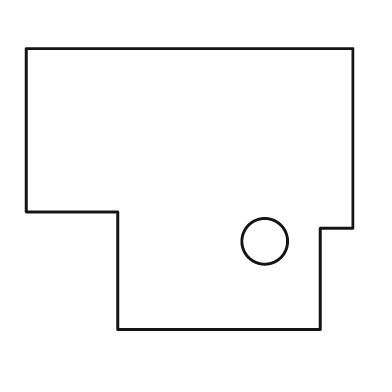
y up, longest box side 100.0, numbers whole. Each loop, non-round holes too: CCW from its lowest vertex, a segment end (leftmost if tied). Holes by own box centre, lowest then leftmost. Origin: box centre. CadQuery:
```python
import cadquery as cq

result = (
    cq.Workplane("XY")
    .moveTo(-22.0, -43.0)
    .lineTo(40.0, -43.0)
    .lineTo(40.0, -12.0)
    .lineTo(50.0, -12.0)
    .lineTo(50.0, 43.0)
    .lineTo(-50.0, 43.0)
    .lineTo(-50.0, -7.0)
    .lineTo(-22.0, -7.0)
    .close()
    .moveTo(23.0, -16.0)
    .circle(7.0)
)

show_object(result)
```